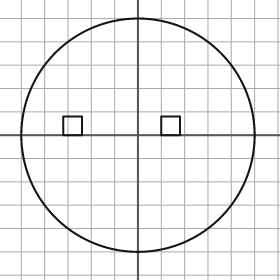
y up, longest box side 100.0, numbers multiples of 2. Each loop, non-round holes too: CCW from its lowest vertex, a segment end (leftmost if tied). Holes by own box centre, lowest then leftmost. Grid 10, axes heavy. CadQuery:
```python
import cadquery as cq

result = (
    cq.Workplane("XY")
    .moveTo(0.0, 0.0)
    .circle(50.0)
    .moveTo(-32.0, 0.0)
    .lineTo(-24.0, 0.0)
    .lineTo(-24.0, 8.0)
    .lineTo(-32.0, 8.0)
    .close()
    .moveTo(10.0, 0.0)
    .lineTo(18.0, 0.0)
    .lineTo(18.0, 8.0)
    .lineTo(10.0, 8.0)
    .close()
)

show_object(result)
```